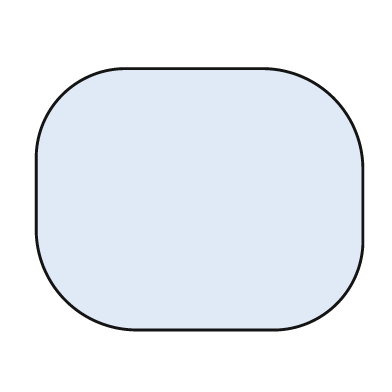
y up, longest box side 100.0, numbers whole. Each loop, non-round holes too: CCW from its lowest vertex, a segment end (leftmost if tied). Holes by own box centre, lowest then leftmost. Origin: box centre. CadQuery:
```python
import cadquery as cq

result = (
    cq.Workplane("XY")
    .moveTo(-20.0, -40.0)
    .lineTo(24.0, -40.0)
    .threePointArc((42.0, -32.0), (50.0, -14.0))
    .lineTo(50.0, 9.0)
    .threePointArc((41.0, 31.0), (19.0, 40.0))
    .lineTo(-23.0, 40.0)
    .threePointArc((-42.0, 32.0), (-50.0, 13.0))
    .lineTo(-50.0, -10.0)
    .threePointArc((-41.0, -31.0), (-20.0, -40.0))
    .close()
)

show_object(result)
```